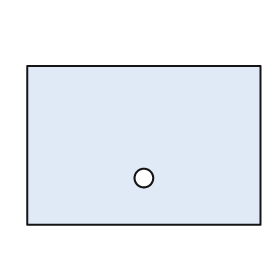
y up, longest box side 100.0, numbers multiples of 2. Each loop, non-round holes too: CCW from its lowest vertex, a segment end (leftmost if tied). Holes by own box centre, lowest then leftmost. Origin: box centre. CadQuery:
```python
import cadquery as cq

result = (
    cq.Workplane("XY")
    .moveTo(-50.0, -34.0)
    .lineTo(50.0, -34.0)
    .lineTo(50.0, 34.0)
    .lineTo(-50.0, 34.0)
    .close()
    .moveTo(0.0, -14.0)
    .circle(4.0)
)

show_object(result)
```